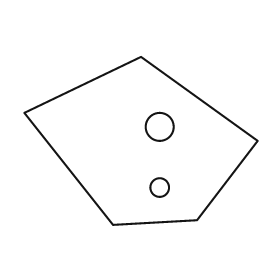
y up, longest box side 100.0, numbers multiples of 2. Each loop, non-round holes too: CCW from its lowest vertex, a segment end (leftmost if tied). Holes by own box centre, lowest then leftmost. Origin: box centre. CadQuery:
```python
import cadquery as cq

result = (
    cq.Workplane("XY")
    .moveTo(-12.0, -36.0)
    .lineTo(24.0, -34.0)
    .lineTo(50.0, 0.0)
    .lineTo(0.0, 36.0)
    .lineTo(-50.0, 12.0)
    .close()
    .moveTo(8.0, -20.0)
    .circle(4.0)
    .moveTo(8.0, 6.0)
    .circle(6.0)
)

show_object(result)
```